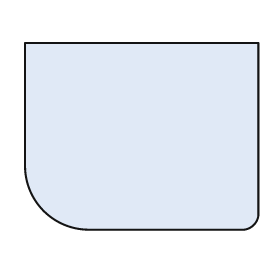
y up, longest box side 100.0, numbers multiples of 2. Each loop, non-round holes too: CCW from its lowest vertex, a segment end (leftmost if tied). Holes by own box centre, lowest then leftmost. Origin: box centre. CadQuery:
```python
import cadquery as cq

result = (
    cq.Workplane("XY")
    .moveTo(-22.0, -40.0)
    .lineTo(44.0, -40.0)
    .threePointArc((48.0, -38.0), (50.0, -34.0))
    .lineTo(50.0, 40.0)
    .lineTo(-50.0, 40.0)
    .lineTo(-50.0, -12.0)
    .threePointArc((-42.0, -32.0), (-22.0, -40.0))
    .close()
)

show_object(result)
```